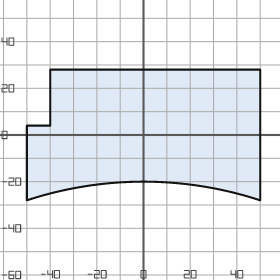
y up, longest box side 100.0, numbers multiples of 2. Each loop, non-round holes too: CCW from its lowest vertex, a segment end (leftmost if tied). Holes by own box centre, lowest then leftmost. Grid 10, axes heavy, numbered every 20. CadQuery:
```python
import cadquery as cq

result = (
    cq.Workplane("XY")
    .moveTo(-50.0, -28.0)
    .threePointArc((0.0, -20.0), (50.0, -28.0))
    .lineTo(50.0, 28.0)
    .lineTo(-40.0, 28.0)
    .lineTo(-40.0, 4.0)
    .lineTo(-50.0, 4.0)
    .close()
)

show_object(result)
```